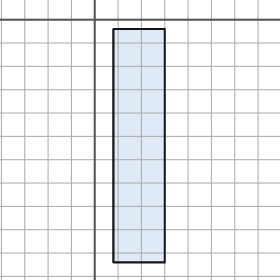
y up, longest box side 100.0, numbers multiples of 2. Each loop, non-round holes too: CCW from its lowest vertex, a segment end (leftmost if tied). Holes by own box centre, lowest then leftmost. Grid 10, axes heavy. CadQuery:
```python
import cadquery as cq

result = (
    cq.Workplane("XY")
    .moveTo(8.0, -104.0)
    .lineTo(30.0, -104.0)
    .lineTo(30.0, -4.0)
    .lineTo(8.0, -4.0)
    .close()
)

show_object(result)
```